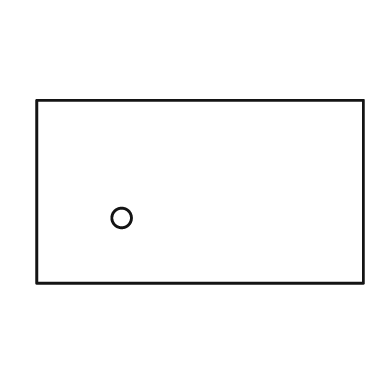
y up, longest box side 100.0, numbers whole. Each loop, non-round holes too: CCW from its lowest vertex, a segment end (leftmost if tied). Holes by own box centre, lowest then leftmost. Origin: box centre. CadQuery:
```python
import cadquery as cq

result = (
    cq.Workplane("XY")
    .moveTo(-50.0, -28.0)
    .lineTo(50.0, -28.0)
    .lineTo(50.0, 28.0)
    .lineTo(-50.0, 28.0)
    .close()
    .moveTo(-24.0, -8.0)
    .circle(3.0)
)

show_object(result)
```